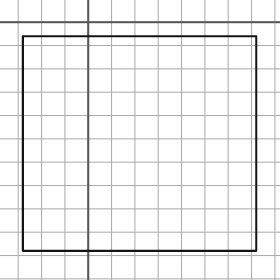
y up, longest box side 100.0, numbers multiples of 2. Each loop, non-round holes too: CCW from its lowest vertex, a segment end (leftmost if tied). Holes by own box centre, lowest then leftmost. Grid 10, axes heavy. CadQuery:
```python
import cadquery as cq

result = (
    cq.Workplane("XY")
    .moveTo(-28.0, -98.0)
    .lineTo(72.0, -98.0)
    .lineTo(72.0, -6.0)
    .lineTo(-28.0, -6.0)
    .close()
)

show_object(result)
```